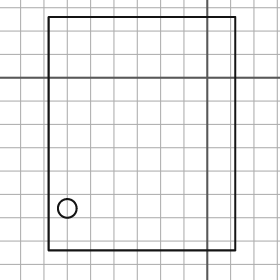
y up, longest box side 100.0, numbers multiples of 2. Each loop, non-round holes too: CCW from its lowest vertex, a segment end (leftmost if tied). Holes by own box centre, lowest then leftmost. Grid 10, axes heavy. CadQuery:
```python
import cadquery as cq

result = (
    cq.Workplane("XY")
    .moveTo(-68.0, -74.0)
    .lineTo(12.0, -74.0)
    .lineTo(12.0, 26.0)
    .lineTo(-68.0, 26.0)
    .close()
    .moveTo(-60.0, -56.0)
    .circle(4.0)
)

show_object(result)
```